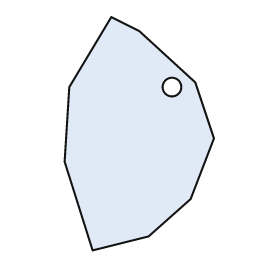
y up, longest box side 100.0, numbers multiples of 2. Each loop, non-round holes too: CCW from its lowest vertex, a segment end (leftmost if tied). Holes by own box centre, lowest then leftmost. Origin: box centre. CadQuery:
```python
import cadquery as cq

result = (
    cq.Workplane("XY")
    .moveTo(-20.0, -50.0)
    .lineTo(4.0, -44.0)
    .lineTo(22.0, -28.0)
    .lineTo(32.0, -2.0)
    .lineTo(24.0, 22.0)
    .lineTo(0.0, 44.0)
    .lineTo(-12.0, 50.0)
    .lineTo(-30.0, 20.0)
    .lineTo(-32.0, -12.0)
    .close()
    .moveTo(14.0, 20.0)
    .circle(4.0)
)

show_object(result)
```